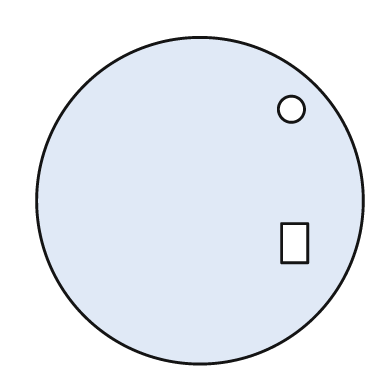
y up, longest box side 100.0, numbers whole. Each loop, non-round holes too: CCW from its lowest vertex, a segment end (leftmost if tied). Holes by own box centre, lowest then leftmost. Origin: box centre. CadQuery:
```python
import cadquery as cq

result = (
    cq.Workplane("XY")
    .moveTo(0.0, 0.0)
    .circle(50.0)
    .moveTo(25.0, -19.0)
    .lineTo(33.0, -19.0)
    .lineTo(33.0, -7.0)
    .lineTo(25.0, -7.0)
    .close()
    .moveTo(28.0, 28.0)
    .circle(4.0)
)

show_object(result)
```